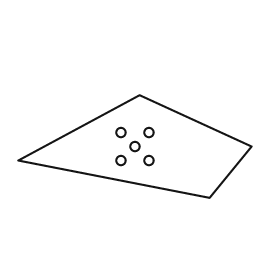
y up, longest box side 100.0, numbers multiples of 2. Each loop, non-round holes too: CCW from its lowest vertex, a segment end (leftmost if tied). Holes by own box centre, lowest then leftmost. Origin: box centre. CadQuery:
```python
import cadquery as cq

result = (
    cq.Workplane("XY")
    .moveTo(32.0, -22.0)
    .lineTo(50.0, 0.0)
    .lineTo(2.0, 22.0)
    .lineTo(-50.0, -6.0)
    .close()
    .moveTo(-6.0, -6.0)
    .circle(2.0)
    .moveTo(6.0, -6.0)
    .circle(2.0)
    .moveTo(0.0, 0.0)
    .circle(2.0)
    .moveTo(-6.0, 6.0)
    .circle(2.0)
    .moveTo(6.0, 6.0)
    .circle(2.0)
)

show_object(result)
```